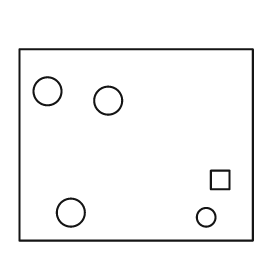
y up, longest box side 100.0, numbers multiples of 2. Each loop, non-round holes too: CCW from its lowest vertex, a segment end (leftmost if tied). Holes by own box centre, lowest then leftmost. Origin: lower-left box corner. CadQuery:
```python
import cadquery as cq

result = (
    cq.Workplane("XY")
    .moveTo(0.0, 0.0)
    .lineTo(100.0, 0.0)
    .lineTo(100.0, 82.0)
    .lineTo(0.0, 82.0)
    .close()
    .moveTo(80.0, 10.0)
    .circle(4.0)
    .moveTo(22.0, 12.0)
    .circle(6.0)
    .moveTo(82.0, 22.0)
    .lineTo(90.0, 22.0)
    .lineTo(90.0, 30.0)
    .lineTo(82.0, 30.0)
    .close()
    .moveTo(38.0, 60.0)
    .circle(6.0)
    .moveTo(12.0, 64.0)
    .circle(6.0)
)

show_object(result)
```